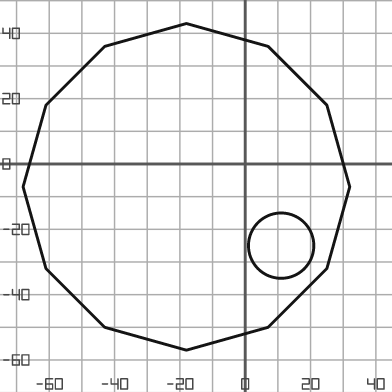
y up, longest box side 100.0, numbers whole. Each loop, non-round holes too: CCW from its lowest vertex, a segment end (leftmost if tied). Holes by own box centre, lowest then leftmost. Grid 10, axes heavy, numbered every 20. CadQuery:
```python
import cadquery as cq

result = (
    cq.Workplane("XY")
    .moveTo(-18.0, -57.0)
    .lineTo(7.0, -50.0)
    .lineTo(25.0, -32.0)
    .lineTo(32.0, -7.0)
    .lineTo(25.0, 18.0)
    .lineTo(7.0, 36.0)
    .lineTo(-18.0, 43.0)
    .lineTo(-43.0, 36.0)
    .lineTo(-61.0, 18.0)
    .lineTo(-68.0, -7.0)
    .lineTo(-61.0, -32.0)
    .lineTo(-43.0, -50.0)
    .close()
    .moveTo(11.0, -25.0)
    .circle(10.0)
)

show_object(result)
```